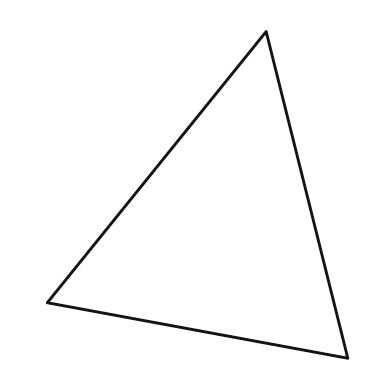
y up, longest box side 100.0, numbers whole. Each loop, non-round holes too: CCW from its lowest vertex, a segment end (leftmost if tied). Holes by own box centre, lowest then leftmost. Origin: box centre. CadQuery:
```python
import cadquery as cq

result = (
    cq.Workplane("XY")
    .moveTo(46.0, -50.0)
    .lineTo(21.0, 50.0)
    .lineTo(-46.0, -33.0)
    .close()
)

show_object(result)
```